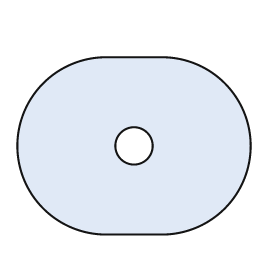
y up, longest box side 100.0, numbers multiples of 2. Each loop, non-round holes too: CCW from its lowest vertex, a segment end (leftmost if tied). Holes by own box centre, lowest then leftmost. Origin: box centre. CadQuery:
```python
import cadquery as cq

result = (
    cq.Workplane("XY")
    .moveTo(-12.0, -38.0)
    .lineTo(12.0, -38.0)
    .threePointArc((50.0, 0.0), (12.0, 38.0))
    .lineTo(-12.0, 38.0)
    .threePointArc((-50.0, 0.0), (-12.0, -38.0))
    .close()
    .moveTo(0.0, 0.0)
    .circle(8.0)
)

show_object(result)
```